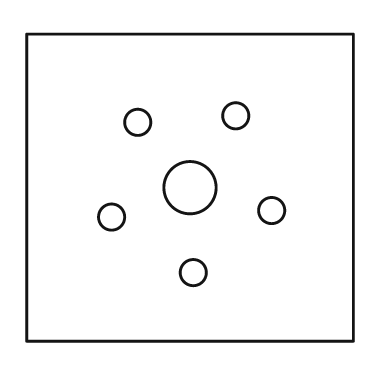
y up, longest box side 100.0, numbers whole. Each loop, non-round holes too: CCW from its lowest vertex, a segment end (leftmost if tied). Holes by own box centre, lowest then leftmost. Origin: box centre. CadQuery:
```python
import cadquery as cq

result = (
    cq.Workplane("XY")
    .moveTo(-50.0, -47.0)
    .lineTo(50.0, -47.0)
    .lineTo(50.0, 47.0)
    .lineTo(-50.0, 47.0)
    .close()
    .moveTo(1.0, -26.0)
    .circle(4.0)
    .moveTo(-24.0, -9.0)
    .circle(4.0)
    .moveTo(25.0, -7.0)
    .circle(4.0)
    .moveTo(0.0, 0.0)
    .circle(8.0)
    .moveTo(-16.0, 20.0)
    .circle(4.0)
    .moveTo(14.0, 22.0)
    .circle(4.0)
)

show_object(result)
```